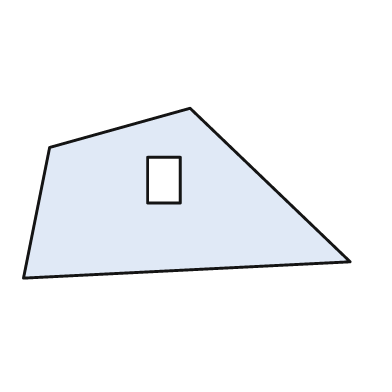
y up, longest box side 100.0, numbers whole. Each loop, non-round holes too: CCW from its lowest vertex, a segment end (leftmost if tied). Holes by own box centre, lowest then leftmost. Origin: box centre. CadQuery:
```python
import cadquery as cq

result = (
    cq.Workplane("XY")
    .moveTo(-50.0, -26.0)
    .lineTo(50.0, -21.0)
    .lineTo(1.0, 26.0)
    .lineTo(-42.0, 14.0)
    .close()
    .moveTo(-12.0, -3.0)
    .lineTo(-2.0, -3.0)
    .lineTo(-2.0, 11.0)
    .lineTo(-12.0, 11.0)
    .close()
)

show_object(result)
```